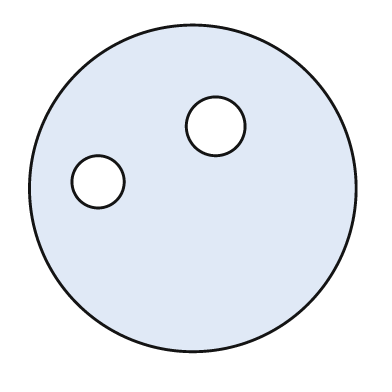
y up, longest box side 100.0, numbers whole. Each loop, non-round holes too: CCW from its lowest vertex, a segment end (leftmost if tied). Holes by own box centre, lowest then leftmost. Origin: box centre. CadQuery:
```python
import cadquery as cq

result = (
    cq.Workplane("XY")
    .moveTo(0.0, 0.0)
    .circle(50.0)
    .moveTo(-29.0, 2.0)
    .circle(8.0)
    .moveTo(7.0, 19.0)
    .circle(9.0)
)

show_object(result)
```